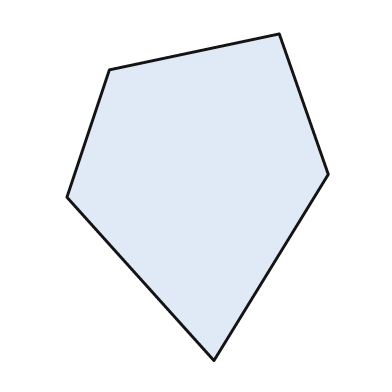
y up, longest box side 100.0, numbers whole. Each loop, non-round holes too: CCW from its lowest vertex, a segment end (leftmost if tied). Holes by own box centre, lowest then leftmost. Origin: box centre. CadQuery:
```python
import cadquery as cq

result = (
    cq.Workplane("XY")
    .moveTo(5.0, -50.0)
    .lineTo(40.0, 7.0)
    .lineTo(25.0, 50.0)
    .lineTo(-27.0, 39.0)
    .lineTo(-40.0, 0.0)
    .close()
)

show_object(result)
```